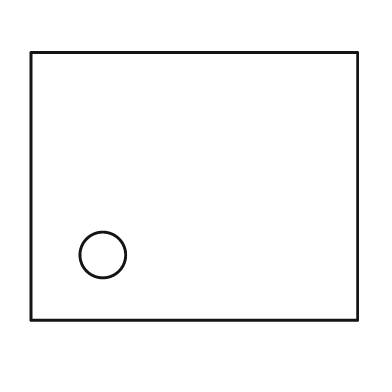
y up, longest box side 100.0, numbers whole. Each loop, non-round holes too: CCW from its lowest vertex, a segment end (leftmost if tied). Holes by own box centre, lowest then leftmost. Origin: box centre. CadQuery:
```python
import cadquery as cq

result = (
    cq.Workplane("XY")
    .moveTo(-50.0, -41.0)
    .lineTo(50.0, -41.0)
    .lineTo(50.0, 41.0)
    .lineTo(-50.0, 41.0)
    .close()
    .moveTo(-28.0, -21.0)
    .circle(7.0)
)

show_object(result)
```